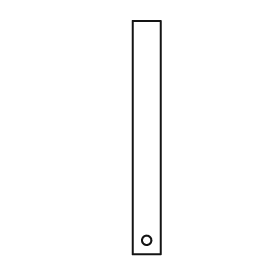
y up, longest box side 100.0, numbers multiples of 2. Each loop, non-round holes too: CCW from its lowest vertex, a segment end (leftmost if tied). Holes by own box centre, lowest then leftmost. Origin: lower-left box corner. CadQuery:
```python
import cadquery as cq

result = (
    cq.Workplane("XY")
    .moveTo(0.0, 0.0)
    .lineTo(12.0, 0.0)
    .lineTo(12.0, 100.0)
    .lineTo(0.0, 100.0)
    .close()
    .moveTo(6.0, 6.0)
    .circle(2.0)
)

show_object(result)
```